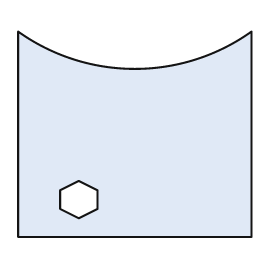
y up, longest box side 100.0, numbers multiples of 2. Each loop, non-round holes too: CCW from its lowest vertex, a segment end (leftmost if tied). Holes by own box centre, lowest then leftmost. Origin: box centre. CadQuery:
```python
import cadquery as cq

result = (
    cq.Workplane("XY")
    .moveTo(-50.0, -44.0)
    .lineTo(50.0, -44.0)
    .lineTo(50.0, 44.0)
    .threePointArc((0.0, 28.0), (-50.0, 44.0))
    .close()
    .moveTo(-24.0, -36.0)
    .lineTo(-16.0, -32.0)
    .lineTo(-16.0, -24.0)
    .lineTo(-24.0, -20.0)
    .lineTo(-32.0, -24.0)
    .lineTo(-32.0, -32.0)
    .close()
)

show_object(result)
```